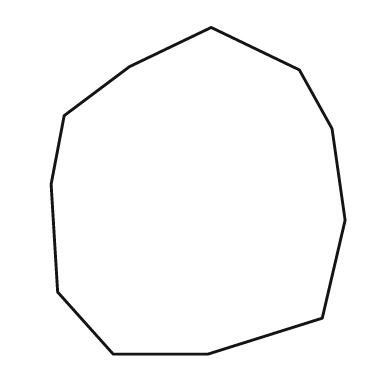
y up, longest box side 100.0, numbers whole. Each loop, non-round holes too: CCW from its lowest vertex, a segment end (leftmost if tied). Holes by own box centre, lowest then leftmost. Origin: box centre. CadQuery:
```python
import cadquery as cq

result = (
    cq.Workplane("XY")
    .moveTo(-26.0, -50.0)
    .lineTo(3.0, -50.0)
    .lineTo(38.0, -39.0)
    .lineTo(45.0, -9.0)
    .lineTo(41.0, 19.0)
    .lineTo(31.0, 37.0)
    .lineTo(4.0, 50.0)
    .lineTo(-21.0, 38.0)
    .lineTo(-41.0, 23.0)
    .lineTo(-45.0, 2.0)
    .lineTo(-43.0, -31.0)
    .close()
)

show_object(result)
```